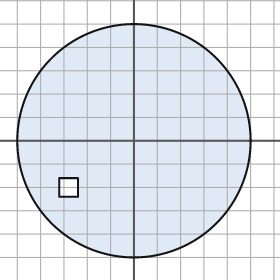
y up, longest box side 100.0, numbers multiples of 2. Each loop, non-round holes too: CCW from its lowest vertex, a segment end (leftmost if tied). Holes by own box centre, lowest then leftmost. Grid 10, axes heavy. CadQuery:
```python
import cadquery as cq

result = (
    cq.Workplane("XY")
    .moveTo(0.0, 0.0)
    .circle(50.0)
    .moveTo(-32.0, -24.0)
    .lineTo(-24.0, -24.0)
    .lineTo(-24.0, -16.0)
    .lineTo(-32.0, -16.0)
    .close()
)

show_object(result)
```